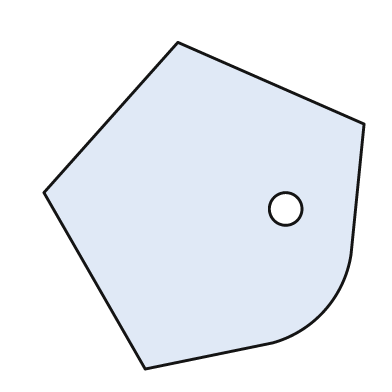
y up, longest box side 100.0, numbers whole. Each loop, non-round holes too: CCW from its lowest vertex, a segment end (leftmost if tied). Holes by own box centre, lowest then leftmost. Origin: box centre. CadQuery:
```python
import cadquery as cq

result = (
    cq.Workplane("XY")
    .moveTo(-18.0, -50.0)
    .lineTo(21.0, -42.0)
    .threePointArc((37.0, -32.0), (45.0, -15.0))
    .lineTo(49.0, 25.0)
    .lineTo(-8.0, 50.0)
    .lineTo(-49.0, 4.0)
    .close()
    .moveTo(25.0, -1.0)
    .circle(5.0)
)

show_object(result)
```